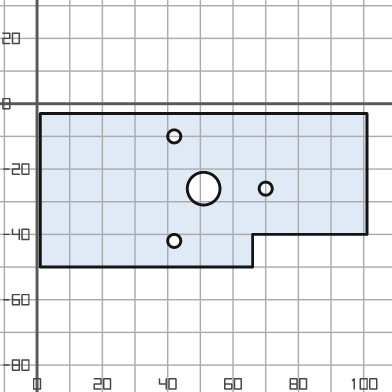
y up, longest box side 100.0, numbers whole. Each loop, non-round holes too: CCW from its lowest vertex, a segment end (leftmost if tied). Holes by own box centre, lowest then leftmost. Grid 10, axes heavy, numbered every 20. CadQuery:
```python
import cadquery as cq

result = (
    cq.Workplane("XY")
    .moveTo(1.0, -50.0)
    .lineTo(66.0, -50.0)
    .lineTo(66.0, -40.0)
    .lineTo(101.0, -40.0)
    .lineTo(101.0, -3.0)
    .lineTo(1.0, -3.0)
    .close()
    .moveTo(42.0, -42.0)
    .circle(2.0)
    .moveTo(51.0, -26.0)
    .circle(5.0)
    .moveTo(70.0, -26.0)
    .circle(2.0)
    .moveTo(42.0, -10.0)
    .circle(2.0)
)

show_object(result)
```